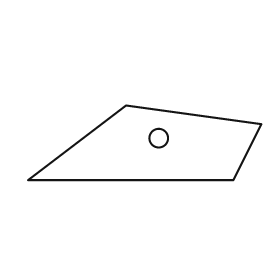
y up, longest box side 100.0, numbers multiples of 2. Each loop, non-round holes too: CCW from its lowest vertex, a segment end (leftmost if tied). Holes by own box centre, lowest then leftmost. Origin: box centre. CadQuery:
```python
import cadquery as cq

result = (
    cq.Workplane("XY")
    .moveTo(-50.0, -16.0)
    .lineTo(38.0, -16.0)
    .lineTo(50.0, 8.0)
    .lineTo(-8.0, 16.0)
    .close()
    .moveTo(6.0, 2.0)
    .circle(4.0)
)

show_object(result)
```